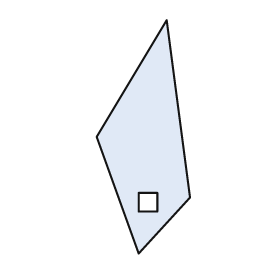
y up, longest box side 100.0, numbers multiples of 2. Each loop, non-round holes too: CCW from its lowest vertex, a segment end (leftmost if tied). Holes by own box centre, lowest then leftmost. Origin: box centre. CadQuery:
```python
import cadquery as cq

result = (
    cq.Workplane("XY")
    .moveTo(-2.0, -50.0)
    .lineTo(20.0, -26.0)
    .lineTo(10.0, 50.0)
    .lineTo(-20.0, 0.0)
    .close()
    .moveTo(-2.0, -32.0)
    .lineTo(6.0, -32.0)
    .lineTo(6.0, -24.0)
    .lineTo(-2.0, -24.0)
    .close()
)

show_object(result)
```